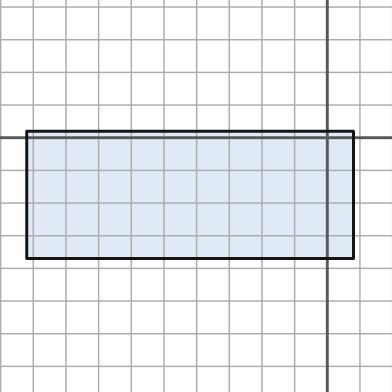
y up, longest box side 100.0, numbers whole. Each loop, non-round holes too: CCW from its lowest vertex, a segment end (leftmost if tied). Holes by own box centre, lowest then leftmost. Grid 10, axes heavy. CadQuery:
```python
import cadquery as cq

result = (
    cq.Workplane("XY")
    .moveTo(-92.0, -37.0)
    .lineTo(8.0, -37.0)
    .lineTo(8.0, 2.0)
    .lineTo(-92.0, 2.0)
    .close()
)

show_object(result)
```